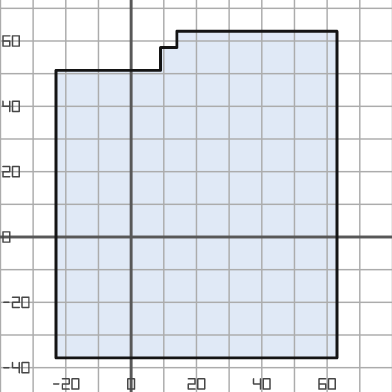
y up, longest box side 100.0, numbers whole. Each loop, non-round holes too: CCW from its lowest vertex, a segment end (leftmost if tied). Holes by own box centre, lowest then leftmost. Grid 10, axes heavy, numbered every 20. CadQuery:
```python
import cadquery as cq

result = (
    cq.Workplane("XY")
    .moveTo(-23.0, -37.0)
    .lineTo(63.0, -37.0)
    .lineTo(63.0, 63.0)
    .lineTo(14.0, 63.0)
    .lineTo(14.0, 58.0)
    .lineTo(9.0, 58.0)
    .lineTo(9.0, 51.0)
    .lineTo(-23.0, 51.0)
    .close()
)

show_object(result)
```